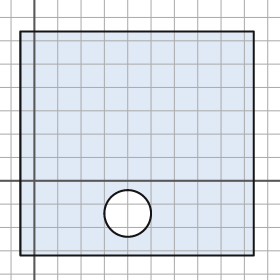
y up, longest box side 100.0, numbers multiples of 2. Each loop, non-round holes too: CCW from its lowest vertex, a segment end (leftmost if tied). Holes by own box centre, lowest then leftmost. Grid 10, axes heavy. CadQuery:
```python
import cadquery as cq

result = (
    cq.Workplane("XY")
    .moveTo(-6.0, -32.0)
    .lineTo(94.0, -32.0)
    .lineTo(94.0, 64.0)
    .lineTo(-6.0, 64.0)
    .close()
    .moveTo(40.0, -14.0)
    .circle(10.0)
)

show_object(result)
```